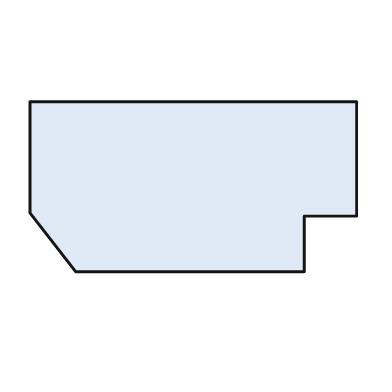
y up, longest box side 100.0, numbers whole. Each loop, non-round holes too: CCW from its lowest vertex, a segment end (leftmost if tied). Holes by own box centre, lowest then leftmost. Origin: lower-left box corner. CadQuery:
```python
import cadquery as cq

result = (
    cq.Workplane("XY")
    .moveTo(14.0, 0.0)
    .lineTo(84.0, 0.0)
    .lineTo(84.0, 17.0)
    .lineTo(100.0, 17.0)
    .lineTo(100.0, 52.0)
    .lineTo(0.0, 52.0)
    .lineTo(0.0, 18.0)
    .close()
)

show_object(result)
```